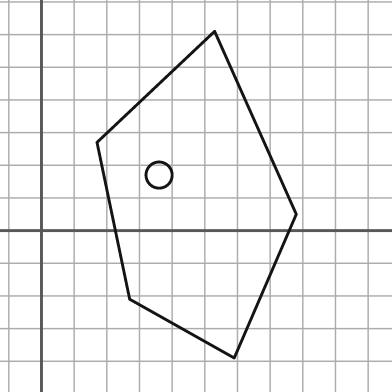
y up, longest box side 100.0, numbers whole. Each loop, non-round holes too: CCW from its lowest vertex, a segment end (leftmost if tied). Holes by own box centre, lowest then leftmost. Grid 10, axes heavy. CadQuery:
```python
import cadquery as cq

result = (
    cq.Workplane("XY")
    .moveTo(59.0, -39.0)
    .lineTo(78.0, 5.0)
    .lineTo(53.0, 61.0)
    .lineTo(17.0, 27.0)
    .lineTo(27.0, -21.0)
    .close()
    .moveTo(36.0, 17.0)
    .circle(4.0)
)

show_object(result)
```